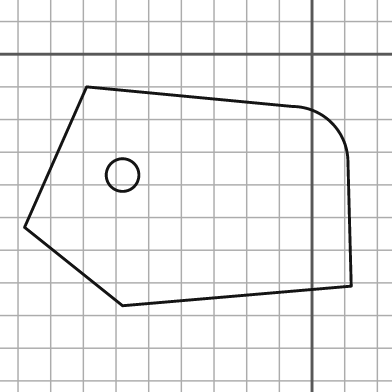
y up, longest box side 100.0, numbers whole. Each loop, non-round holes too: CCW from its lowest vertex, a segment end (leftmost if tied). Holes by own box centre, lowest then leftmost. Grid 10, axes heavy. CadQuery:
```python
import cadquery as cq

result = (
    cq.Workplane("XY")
    .moveTo(-58.0, -77.0)
    .lineTo(12.0, -71.0)
    .lineTo(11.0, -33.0)
    .threePointArc((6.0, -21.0), (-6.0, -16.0))
    .lineTo(-69.0, -10.0)
    .lineTo(-88.0, -53.0)
    .close()
    .moveTo(-58.0, -37.0)
    .circle(5.0)
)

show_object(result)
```